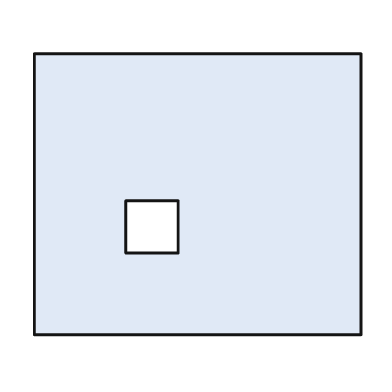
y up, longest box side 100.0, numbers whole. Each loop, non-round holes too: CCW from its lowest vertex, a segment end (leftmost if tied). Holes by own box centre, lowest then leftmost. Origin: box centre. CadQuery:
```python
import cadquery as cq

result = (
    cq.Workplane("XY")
    .moveTo(-50.0, -43.0)
    .lineTo(50.0, -43.0)
    .lineTo(50.0, 43.0)
    .lineTo(-50.0, 43.0)
    .close()
    .moveTo(-22.0, -18.0)
    .lineTo(-6.0, -18.0)
    .lineTo(-6.0, -2.0)
    .lineTo(-22.0, -2.0)
    .close()
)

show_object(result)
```